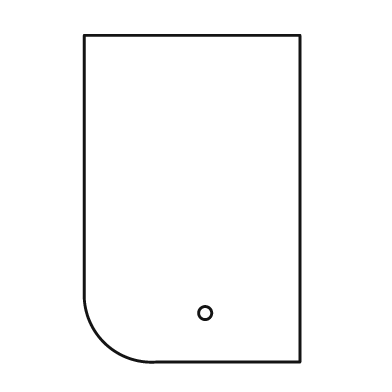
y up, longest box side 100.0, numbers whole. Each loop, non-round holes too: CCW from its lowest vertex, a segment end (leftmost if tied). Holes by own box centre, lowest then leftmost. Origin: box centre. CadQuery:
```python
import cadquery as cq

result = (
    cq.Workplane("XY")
    .moveTo(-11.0, -50.0)
    .lineTo(33.0, -50.0)
    .lineTo(33.0, 50.0)
    .lineTo(-33.0, 50.0)
    .lineTo(-33.0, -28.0)
    .threePointArc((-27.0, -44.0), (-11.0, -50.0))
    .close()
    .moveTo(4.0, -35.0)
    .circle(2.0)
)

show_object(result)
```